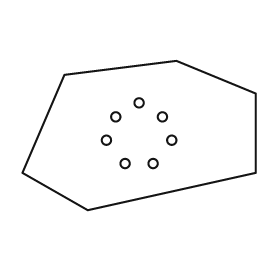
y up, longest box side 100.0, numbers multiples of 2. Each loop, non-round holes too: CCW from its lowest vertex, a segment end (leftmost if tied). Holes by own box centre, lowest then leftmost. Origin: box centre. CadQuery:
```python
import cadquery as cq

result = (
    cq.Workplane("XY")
    .moveTo(-22.0, -32.0)
    .lineTo(50.0, -16.0)
    .lineTo(50.0, 18.0)
    .lineTo(16.0, 32.0)
    .lineTo(-32.0, 26.0)
    .lineTo(-50.0, -16.0)
    .close()
    .moveTo(-6.0, -12.0)
    .circle(2.0)
    .moveTo(6.0, -12.0)
    .circle(2.0)
    .moveTo(-14.0, -2.0)
    .circle(2.0)
    .moveTo(14.0, -2.0)
    .circle(2.0)
    .moveTo(-10.0, 8.0)
    .circle(2.0)
    .moveTo(10.0, 8.0)
    .circle(2.0)
    .moveTo(0.0, 14.0)
    .circle(2.0)
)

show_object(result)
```